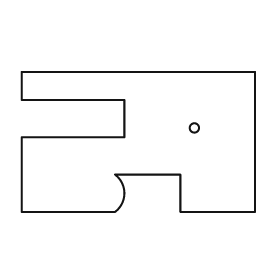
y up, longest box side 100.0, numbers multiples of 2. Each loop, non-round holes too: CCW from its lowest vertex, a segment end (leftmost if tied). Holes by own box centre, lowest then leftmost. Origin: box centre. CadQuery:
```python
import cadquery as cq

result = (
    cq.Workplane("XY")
    .moveTo(-50.0, -30.0)
    .lineTo(-10.0, -30.0)
    .threePointArc((-6.0, -22.0), (-10.0, -14.0))
    .lineTo(18.0, -14.0)
    .lineTo(18.0, -30.0)
    .lineTo(50.0, -30.0)
    .lineTo(50.0, 30.0)
    .lineTo(-50.0, 30.0)
    .lineTo(-50.0, 18.0)
    .lineTo(-6.0, 18.0)
    .lineTo(-6.0, 2.0)
    .lineTo(-50.0, 2.0)
    .close()
    .moveTo(24.0, 6.0)
    .circle(2.0)
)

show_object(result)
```